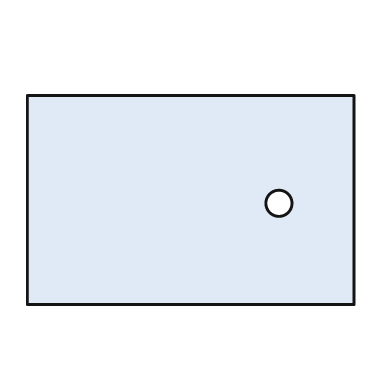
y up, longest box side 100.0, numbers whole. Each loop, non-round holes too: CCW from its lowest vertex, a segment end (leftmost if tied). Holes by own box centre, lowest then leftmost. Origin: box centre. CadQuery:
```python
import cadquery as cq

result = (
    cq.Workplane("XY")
    .moveTo(-50.0, -32.0)
    .lineTo(50.0, -32.0)
    .lineTo(50.0, 32.0)
    .lineTo(-50.0, 32.0)
    .close()
    .moveTo(27.0, -1.0)
    .circle(4.0)
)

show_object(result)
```